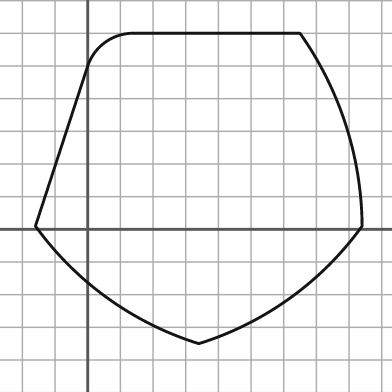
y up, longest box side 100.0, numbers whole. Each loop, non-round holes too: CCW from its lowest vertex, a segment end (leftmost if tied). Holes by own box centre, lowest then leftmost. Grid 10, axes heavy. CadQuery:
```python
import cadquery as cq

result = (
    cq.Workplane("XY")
    .moveTo(34.0, -35.0)
    .threePointArc((62.0, -21.0), (84.0, 1.0))
    .threePointArc((79.0, 32.0), (65.0, 60.0))
    .lineTo(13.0, 60.0)
    .threePointArc((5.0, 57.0), (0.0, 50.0))
    .lineTo(-16.0, 1.0)
    .threePointArc((6.0, -21.0), (34.0, -35.0))
    .close()
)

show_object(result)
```